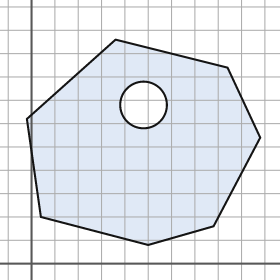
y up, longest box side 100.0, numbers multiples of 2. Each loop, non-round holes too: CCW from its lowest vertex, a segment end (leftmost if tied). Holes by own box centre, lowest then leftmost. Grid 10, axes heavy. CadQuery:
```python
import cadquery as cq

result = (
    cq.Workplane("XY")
    .moveTo(50.0, 8.0)
    .lineTo(78.0, 16.0)
    .lineTo(98.0, 54.0)
    .lineTo(84.0, 84.0)
    .lineTo(36.0, 96.0)
    .lineTo(-2.0, 62.0)
    .lineTo(4.0, 20.0)
    .close()
    .moveTo(48.0, 68.0)
    .circle(10.0)
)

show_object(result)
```